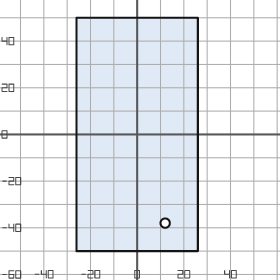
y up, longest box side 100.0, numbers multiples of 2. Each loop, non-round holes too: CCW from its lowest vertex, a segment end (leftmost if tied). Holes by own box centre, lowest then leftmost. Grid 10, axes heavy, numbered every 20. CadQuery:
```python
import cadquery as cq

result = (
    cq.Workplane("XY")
    .moveTo(-26.0, -50.0)
    .lineTo(26.0, -50.0)
    .lineTo(26.0, 50.0)
    .lineTo(-26.0, 50.0)
    .close()
    .moveTo(12.0, -38.0)
    .circle(2.0)
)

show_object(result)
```